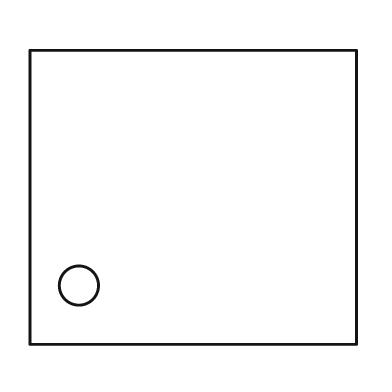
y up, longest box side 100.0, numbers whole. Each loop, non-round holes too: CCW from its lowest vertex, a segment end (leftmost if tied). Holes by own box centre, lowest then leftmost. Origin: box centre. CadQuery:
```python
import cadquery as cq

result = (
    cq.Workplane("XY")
    .moveTo(-50.0, -45.0)
    .lineTo(50.0, -45.0)
    .lineTo(50.0, 45.0)
    .lineTo(-50.0, 45.0)
    .close()
    .moveTo(-35.0, -27.0)
    .circle(6.0)
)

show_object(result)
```